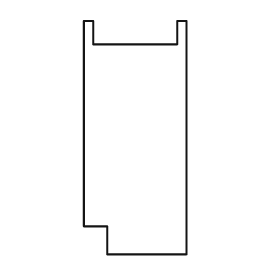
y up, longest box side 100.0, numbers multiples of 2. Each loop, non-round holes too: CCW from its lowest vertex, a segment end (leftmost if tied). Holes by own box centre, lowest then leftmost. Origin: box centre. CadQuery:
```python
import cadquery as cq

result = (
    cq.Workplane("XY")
    .moveTo(-12.0, -50.0)
    .lineTo(22.0, -50.0)
    .lineTo(22.0, 50.0)
    .lineTo(18.0, 50.0)
    .lineTo(18.0, 40.0)
    .lineTo(-18.0, 40.0)
    .lineTo(-18.0, 50.0)
    .lineTo(-22.0, 50.0)
    .lineTo(-22.0, -38.0)
    .lineTo(-12.0, -38.0)
    .close()
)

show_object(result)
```